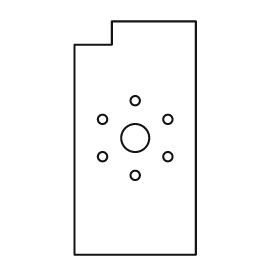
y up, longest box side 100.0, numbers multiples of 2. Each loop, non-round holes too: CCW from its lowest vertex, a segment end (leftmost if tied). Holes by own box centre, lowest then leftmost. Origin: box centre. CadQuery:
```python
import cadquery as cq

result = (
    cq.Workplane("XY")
    .moveTo(-26.0, -50.0)
    .lineTo(26.0, -50.0)
    .lineTo(26.0, 50.0)
    .lineTo(-10.0, 50.0)
    .lineTo(-10.0, 40.0)
    .lineTo(-26.0, 40.0)
    .close()
    .moveTo(0.0, -16.0)
    .circle(2.0)
    .moveTo(-14.0, -8.0)
    .circle(2.0)
    .moveTo(14.0, -8.0)
    .circle(2.0)
    .moveTo(0.0, 0.0)
    .circle(6.0)
    .moveTo(-14.0, 8.0)
    .circle(2.0)
    .moveTo(14.0, 8.0)
    .circle(2.0)
    .moveTo(0.0, 16.0)
    .circle(2.0)
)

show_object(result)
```